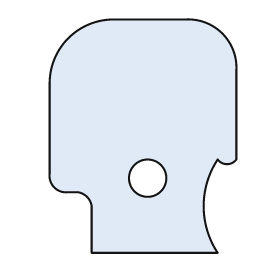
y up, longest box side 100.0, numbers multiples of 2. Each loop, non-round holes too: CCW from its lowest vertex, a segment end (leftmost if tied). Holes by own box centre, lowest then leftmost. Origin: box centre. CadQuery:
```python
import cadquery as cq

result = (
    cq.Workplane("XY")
    .moveTo(-22.0, -50.0)
    .lineTo(32.0, -50.0)
    .threePointArc((26.0, -30.0), (32.0, -10.0))
    .threePointArc((36.0, -12.0), (40.0, -10.0))
    .lineTo(40.0, 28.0)
    .threePointArc((34.0, 44.0), (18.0, 50.0))
    .lineTo(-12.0, 50.0)
    .threePointArc((-32.0, 42.0), (-40.0, 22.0))
    .lineTo(-40.0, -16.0)
    .threePointArc((-38.0, -22.0), (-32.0, -24.0))
    .lineTo(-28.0, -24.0)
    .threePointArc((-24.0, -26.0), (-22.0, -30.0))
    .close()
    .moveTo(2.0, -18.0)
    .circle(8.0)
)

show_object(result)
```